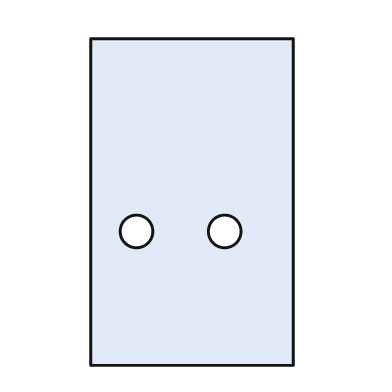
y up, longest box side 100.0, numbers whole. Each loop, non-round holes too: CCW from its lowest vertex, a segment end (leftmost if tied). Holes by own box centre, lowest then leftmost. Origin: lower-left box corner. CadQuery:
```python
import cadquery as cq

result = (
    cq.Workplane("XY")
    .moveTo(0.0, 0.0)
    .lineTo(62.0, 0.0)
    .lineTo(62.0, 100.0)
    .lineTo(0.0, 100.0)
    .close()
    .moveTo(14.0, 41.0)
    .circle(5.0)
    .moveTo(41.0, 41.0)
    .circle(5.0)
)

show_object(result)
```